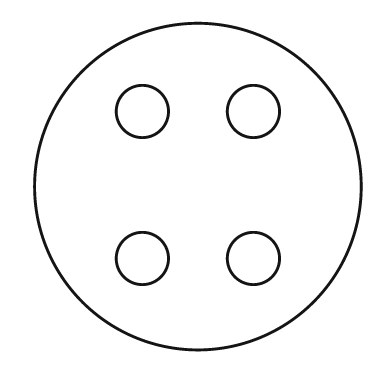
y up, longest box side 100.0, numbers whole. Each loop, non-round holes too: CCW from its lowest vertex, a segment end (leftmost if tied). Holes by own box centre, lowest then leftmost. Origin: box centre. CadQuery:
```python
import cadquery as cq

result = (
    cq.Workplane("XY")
    .moveTo(0.0, 0.0)
    .circle(50.0)
    .moveTo(-17.0, -22.0)
    .circle(8.0)
    .moveTo(17.0, -22.0)
    .circle(8.0)
    .moveTo(-17.0, 23.0)
    .circle(8.0)
    .moveTo(17.0, 23.0)
    .circle(8.0)
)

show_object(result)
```